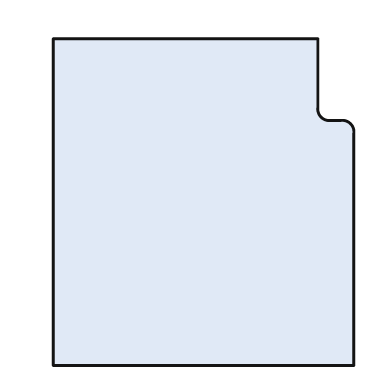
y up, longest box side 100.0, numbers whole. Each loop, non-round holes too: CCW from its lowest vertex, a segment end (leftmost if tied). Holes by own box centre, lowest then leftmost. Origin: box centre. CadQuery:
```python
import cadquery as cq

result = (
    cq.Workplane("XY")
    .moveTo(-46.0, -50.0)
    .lineTo(46.0, -50.0)
    .lineTo(46.0, 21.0)
    .threePointArc((45.0, 24.0), (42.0, 25.0))
    .lineTo(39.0, 25.0)
    .threePointArc((36.0, 26.0), (35.0, 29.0))
    .lineTo(35.0, 50.0)
    .lineTo(-46.0, 50.0)
    .close()
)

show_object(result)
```